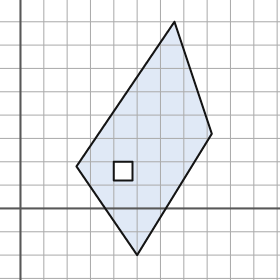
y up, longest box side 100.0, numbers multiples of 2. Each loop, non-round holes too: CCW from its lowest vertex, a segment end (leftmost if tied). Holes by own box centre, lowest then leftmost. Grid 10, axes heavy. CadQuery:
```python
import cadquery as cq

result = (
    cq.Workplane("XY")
    .moveTo(50.0, -20.0)
    .lineTo(82.0, 32.0)
    .lineTo(66.0, 80.0)
    .lineTo(24.0, 18.0)
    .close()
    .moveTo(40.0, 12.0)
    .lineTo(48.0, 12.0)
    .lineTo(48.0, 20.0)
    .lineTo(40.0, 20.0)
    .close()
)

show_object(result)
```